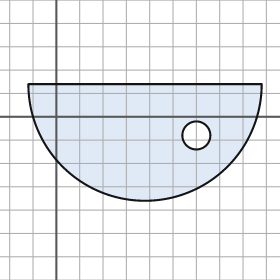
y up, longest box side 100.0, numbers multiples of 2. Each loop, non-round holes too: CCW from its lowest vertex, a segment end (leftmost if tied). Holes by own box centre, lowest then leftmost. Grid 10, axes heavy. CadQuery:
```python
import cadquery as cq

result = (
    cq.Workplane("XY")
    .moveTo(-12.0, 14.0)
    .threePointArc((38.0, -36.0), (88.0, 14.0))
    .close()
    .moveTo(60.0, -8.0)
    .circle(6.0)
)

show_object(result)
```